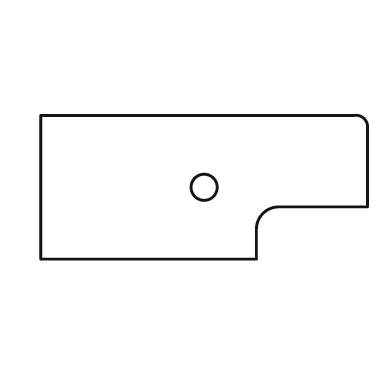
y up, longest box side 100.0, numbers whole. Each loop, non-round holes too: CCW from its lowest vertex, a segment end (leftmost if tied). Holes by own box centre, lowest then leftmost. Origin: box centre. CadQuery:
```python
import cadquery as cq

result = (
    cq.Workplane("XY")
    .moveTo(-50.0, -22.0)
    .lineTo(16.0, -22.0)
    .lineTo(16.0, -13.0)
    .threePointArc((18.0, -8.0), (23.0, -6.0))
    .lineTo(50.0, -6.0)
    .lineTo(50.0, 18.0)
    .threePointArc((49.0, 21.0), (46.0, 22.0))
    .lineTo(-50.0, 22.0)
    .close()
    .moveTo(0.0, 0.0)
    .circle(4.0)
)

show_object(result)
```